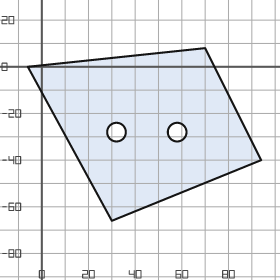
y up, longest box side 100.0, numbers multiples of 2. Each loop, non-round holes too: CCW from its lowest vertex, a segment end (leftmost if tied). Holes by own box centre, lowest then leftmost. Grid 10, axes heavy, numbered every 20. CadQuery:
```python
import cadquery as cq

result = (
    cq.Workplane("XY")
    .moveTo(30.0, -66.0)
    .lineTo(94.0, -40.0)
    .lineTo(70.0, 8.0)
    .lineTo(-6.0, 0.0)
    .close()
    .moveTo(32.0, -28.0)
    .circle(4.0)
    .moveTo(58.0, -28.0)
    .circle(4.0)
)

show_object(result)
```